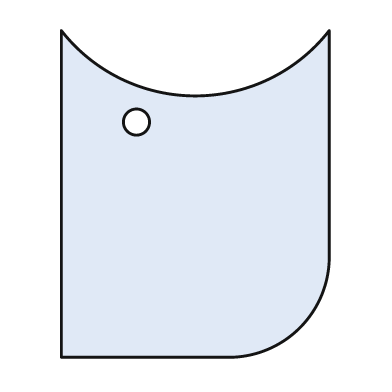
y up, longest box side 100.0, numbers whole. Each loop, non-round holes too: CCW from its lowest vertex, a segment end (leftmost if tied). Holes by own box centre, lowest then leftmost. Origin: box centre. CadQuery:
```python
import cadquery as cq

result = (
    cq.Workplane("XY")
    .moveTo(-41.0, -50.0)
    .lineTo(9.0, -50.0)
    .threePointArc((32.0, -41.0), (41.0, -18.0))
    .lineTo(41.0, 50.0)
    .threePointArc((0.0, 30.0), (-41.0, 50.0))
    .close()
    .moveTo(-18.0, 22.0)
    .circle(4.0)
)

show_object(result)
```